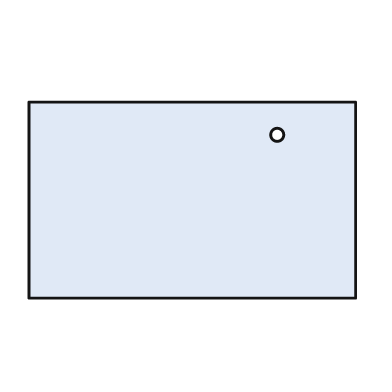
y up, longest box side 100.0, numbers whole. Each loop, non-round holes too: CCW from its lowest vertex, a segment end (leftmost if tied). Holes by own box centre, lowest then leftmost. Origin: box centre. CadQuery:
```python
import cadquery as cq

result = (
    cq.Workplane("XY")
    .moveTo(-50.0, -30.0)
    .lineTo(50.0, -30.0)
    .lineTo(50.0, 30.0)
    .lineTo(-50.0, 30.0)
    .close()
    .moveTo(26.0, 20.0)
    .circle(2.0)
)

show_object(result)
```